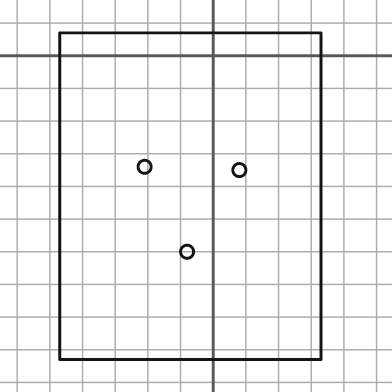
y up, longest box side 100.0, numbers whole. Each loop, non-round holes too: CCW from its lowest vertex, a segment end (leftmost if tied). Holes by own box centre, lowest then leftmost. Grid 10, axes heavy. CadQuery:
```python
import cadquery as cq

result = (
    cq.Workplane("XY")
    .moveTo(-47.0, -93.0)
    .lineTo(33.0, -93.0)
    .lineTo(33.0, 7.0)
    .lineTo(-47.0, 7.0)
    .close()
    .moveTo(-8.0, -60.0)
    .circle(2.0)
    .moveTo(8.0, -35.0)
    .circle(2.0)
    .moveTo(-21.0, -34.0)
    .circle(2.0)
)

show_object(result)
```